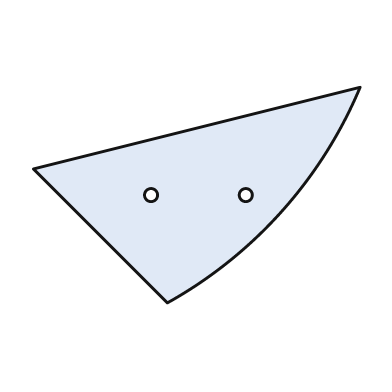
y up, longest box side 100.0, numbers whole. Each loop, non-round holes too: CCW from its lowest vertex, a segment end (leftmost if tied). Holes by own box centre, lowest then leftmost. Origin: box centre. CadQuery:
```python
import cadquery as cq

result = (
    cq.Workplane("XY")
    .moveTo(-9.0, -33.0)
    .threePointArc((26.0, -5.0), (50.0, 33.0))
    .lineTo(-50.0, 8.0)
    .close()
    .moveTo(-14.0, 0.0)
    .circle(2.0)
    .moveTo(15.0, 0.0)
    .circle(2.0)
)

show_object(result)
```